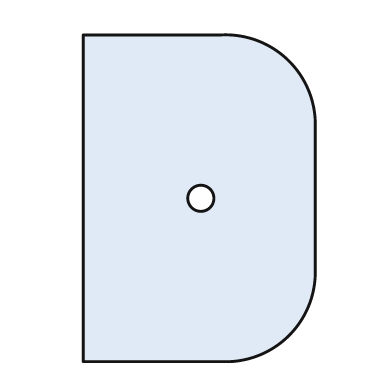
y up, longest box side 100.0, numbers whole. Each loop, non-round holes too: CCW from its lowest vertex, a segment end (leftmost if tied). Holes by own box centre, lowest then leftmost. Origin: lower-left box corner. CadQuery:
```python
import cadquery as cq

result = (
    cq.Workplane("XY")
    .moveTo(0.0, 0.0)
    .lineTo(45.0, 0.0)
    .threePointArc((63.0, 8.0), (71.0, 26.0))
    .lineTo(71.0, 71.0)
    .threePointArc((63.0, 92.0), (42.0, 100.0))
    .lineTo(0.0, 100.0)
    .close()
    .moveTo(36.0, 50.0)
    .circle(4.0)
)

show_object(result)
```